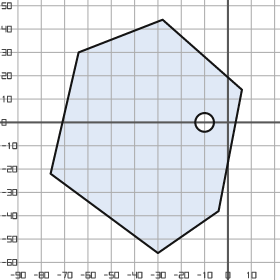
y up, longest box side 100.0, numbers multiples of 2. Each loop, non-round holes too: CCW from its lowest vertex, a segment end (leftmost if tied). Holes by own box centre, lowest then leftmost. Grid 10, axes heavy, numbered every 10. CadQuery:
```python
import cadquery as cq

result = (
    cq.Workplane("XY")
    .moveTo(-30.0, -56.0)
    .lineTo(-4.0, -38.0)
    .lineTo(6.0, 14.0)
    .lineTo(-28.0, 44.0)
    .lineTo(-64.0, 30.0)
    .lineTo(-76.0, -22.0)
    .close()
    .moveTo(-10.0, 0.0)
    .circle(4.0)
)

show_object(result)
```